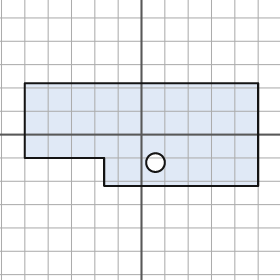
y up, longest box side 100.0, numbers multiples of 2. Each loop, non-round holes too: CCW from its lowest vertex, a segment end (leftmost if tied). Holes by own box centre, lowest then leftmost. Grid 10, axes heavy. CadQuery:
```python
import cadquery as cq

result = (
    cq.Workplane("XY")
    .moveTo(-16.0, -22.0)
    .lineTo(50.0, -22.0)
    .lineTo(50.0, 22.0)
    .lineTo(-50.0, 22.0)
    .lineTo(-50.0, -10.0)
    .lineTo(-16.0, -10.0)
    .close()
    .moveTo(6.0, -12.0)
    .circle(4.0)
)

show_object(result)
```